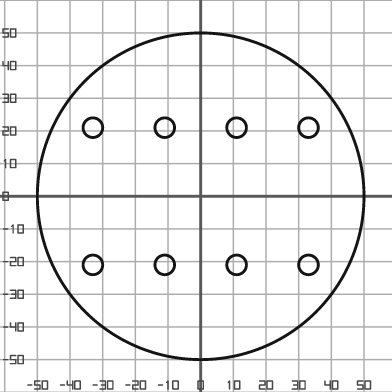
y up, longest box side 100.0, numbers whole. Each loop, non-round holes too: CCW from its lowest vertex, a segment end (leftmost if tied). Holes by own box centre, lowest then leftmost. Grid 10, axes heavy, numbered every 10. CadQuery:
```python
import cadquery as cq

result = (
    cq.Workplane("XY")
    .moveTo(0.0, 0.0)
    .circle(50.0)
    .moveTo(-33.0, -21.0)
    .circle(3.0)
    .moveTo(-11.0, -21.0)
    .circle(3.0)
    .moveTo(11.0, -21.0)
    .circle(3.0)
    .moveTo(33.0, -21.0)
    .circle(3.0)
    .moveTo(-33.0, 21.0)
    .circle(3.0)
    .moveTo(-11.0, 21.0)
    .circle(3.0)
    .moveTo(11.0, 21.0)
    .circle(3.0)
    .moveTo(33.0, 21.0)
    .circle(3.0)
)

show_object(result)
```